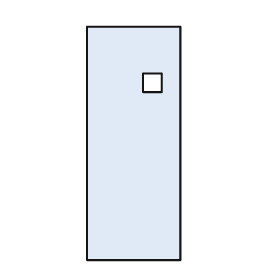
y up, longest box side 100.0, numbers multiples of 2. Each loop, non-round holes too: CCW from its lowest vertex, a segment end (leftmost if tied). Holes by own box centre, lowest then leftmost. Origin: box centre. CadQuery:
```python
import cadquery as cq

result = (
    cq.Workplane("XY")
    .moveTo(-20.0, -50.0)
    .lineTo(20.0, -50.0)
    .lineTo(20.0, 50.0)
    .lineTo(-20.0, 50.0)
    .close()
    .moveTo(4.0, 22.0)
    .lineTo(12.0, 22.0)
    .lineTo(12.0, 30.0)
    .lineTo(4.0, 30.0)
    .close()
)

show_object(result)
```